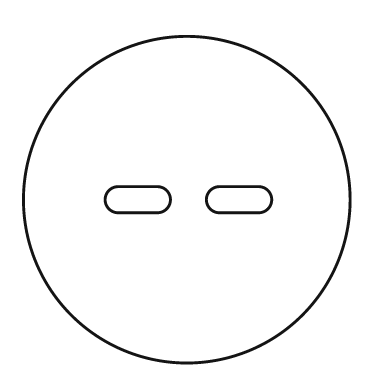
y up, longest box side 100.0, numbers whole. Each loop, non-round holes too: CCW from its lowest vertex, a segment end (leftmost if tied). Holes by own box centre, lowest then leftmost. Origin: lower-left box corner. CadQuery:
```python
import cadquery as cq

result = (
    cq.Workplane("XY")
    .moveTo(50.0, 50.0)
    .circle(50.0)
    .moveTo(29.0, 46.0)
    .lineTo(41.0, 46.0)
    .threePointArc((45.0, 50.0), (41.0, 54.0))
    .lineTo(29.0, 54.0)
    .threePointArc((25.0, 50.0), (29.0, 46.0))
    .close()
    .moveTo(60.0, 46.0)
    .lineTo(72.0, 46.0)
    .threePointArc((76.0, 50.0), (72.0, 54.0))
    .lineTo(60.0, 54.0)
    .threePointArc((56.0, 50.0), (60.0, 46.0))
    .close()
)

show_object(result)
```